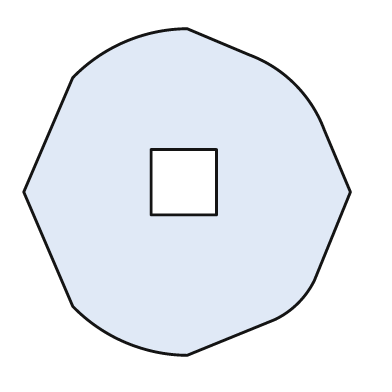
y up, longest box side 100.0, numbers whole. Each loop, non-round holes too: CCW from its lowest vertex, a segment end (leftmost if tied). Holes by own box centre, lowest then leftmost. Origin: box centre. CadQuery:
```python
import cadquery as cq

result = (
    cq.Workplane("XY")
    .moveTo(0.0, -50.0)
    .lineTo(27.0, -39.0)
    .threePointArc((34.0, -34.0), (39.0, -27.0))
    .lineTo(50.0, 0.0)
    .lineTo(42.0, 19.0)
    .threePointArc((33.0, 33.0), (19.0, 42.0))
    .lineTo(0.0, 50.0)
    .threePointArc((-19.0, 46.0), (-35.0, 35.0))
    .lineTo(-50.0, 0.0)
    .lineTo(-35.0, -35.0)
    .threePointArc((-19.0, -46.0), (0.0, -50.0))
    .close()
    .moveTo(-11.0, -7.0)
    .lineTo(9.0, -7.0)
    .lineTo(9.0, 13.0)
    .lineTo(-11.0, 13.0)
    .close()
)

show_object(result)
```